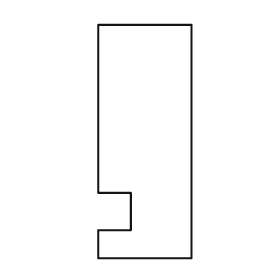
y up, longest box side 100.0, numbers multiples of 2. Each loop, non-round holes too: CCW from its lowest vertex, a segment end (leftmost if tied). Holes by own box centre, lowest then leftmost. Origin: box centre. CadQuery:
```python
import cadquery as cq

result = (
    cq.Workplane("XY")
    .moveTo(-20.0, -50.0)
    .lineTo(20.0, -50.0)
    .lineTo(20.0, 50.0)
    .lineTo(-20.0, 50.0)
    .lineTo(-20.0, -22.0)
    .lineTo(-6.0, -22.0)
    .lineTo(-6.0, -38.0)
    .lineTo(-20.0, -38.0)
    .close()
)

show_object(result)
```